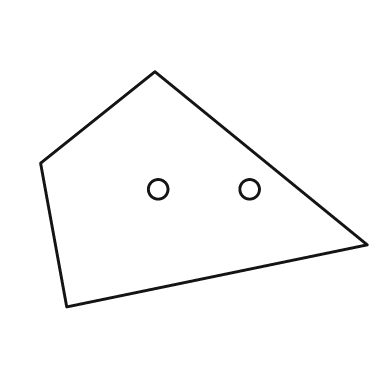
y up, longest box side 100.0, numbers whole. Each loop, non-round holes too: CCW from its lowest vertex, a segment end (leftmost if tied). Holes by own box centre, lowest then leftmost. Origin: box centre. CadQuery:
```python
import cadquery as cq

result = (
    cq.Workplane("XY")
    .moveTo(-42.0, -36.0)
    .lineTo(50.0, -17.0)
    .lineTo(-15.0, 36.0)
    .lineTo(-50.0, 8.0)
    .close()
    .moveTo(-14.0, 0.0)
    .circle(3.0)
    .moveTo(14.0, 0.0)
    .circle(3.0)
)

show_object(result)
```